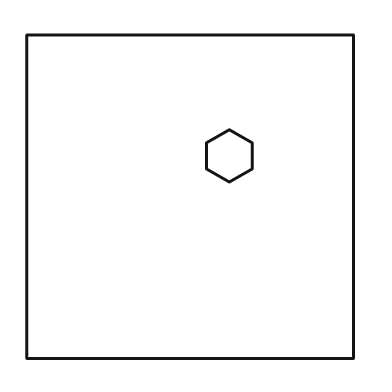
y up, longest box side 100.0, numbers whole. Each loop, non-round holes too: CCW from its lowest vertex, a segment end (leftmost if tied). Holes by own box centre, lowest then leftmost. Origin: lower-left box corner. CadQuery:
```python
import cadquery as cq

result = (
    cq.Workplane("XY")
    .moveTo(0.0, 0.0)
    .lineTo(100.0, 0.0)
    .lineTo(100.0, 99.0)
    .lineTo(0.0, 99.0)
    .close()
    .moveTo(62.0, 54.0)
    .lineTo(69.0, 58.0)
    .lineTo(69.0, 66.0)
    .lineTo(62.0, 70.0)
    .lineTo(55.0, 66.0)
    .lineTo(55.0, 58.0)
    .close()
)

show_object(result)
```